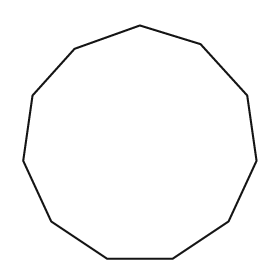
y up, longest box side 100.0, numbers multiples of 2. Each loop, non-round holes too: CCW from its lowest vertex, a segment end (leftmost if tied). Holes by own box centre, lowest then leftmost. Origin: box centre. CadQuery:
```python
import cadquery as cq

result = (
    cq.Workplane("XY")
    .moveTo(-14.0, -50.0)
    .lineTo(14.0, -50.0)
    .lineTo(38.0, -34.0)
    .lineTo(50.0, -8.0)
    .lineTo(46.0, 20.0)
    .lineTo(26.0, 42.0)
    .lineTo(0.0, 50.0)
    .lineTo(-28.0, 40.0)
    .lineTo(-46.0, 20.0)
    .lineTo(-50.0, -8.0)
    .lineTo(-38.0, -34.0)
    .close()
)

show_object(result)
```